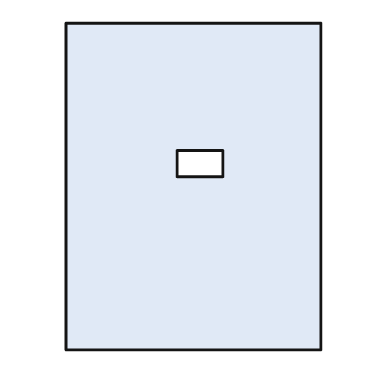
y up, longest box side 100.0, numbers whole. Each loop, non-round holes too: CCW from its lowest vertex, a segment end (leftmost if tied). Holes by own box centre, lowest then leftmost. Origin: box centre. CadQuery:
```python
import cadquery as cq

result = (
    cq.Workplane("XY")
    .moveTo(-39.0, -50.0)
    .lineTo(39.0, -50.0)
    .lineTo(39.0, 50.0)
    .lineTo(-39.0, 50.0)
    .close()
    .moveTo(-5.0, 3.0)
    .lineTo(9.0, 3.0)
    .lineTo(9.0, 11.0)
    .lineTo(-5.0, 11.0)
    .close()
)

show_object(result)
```